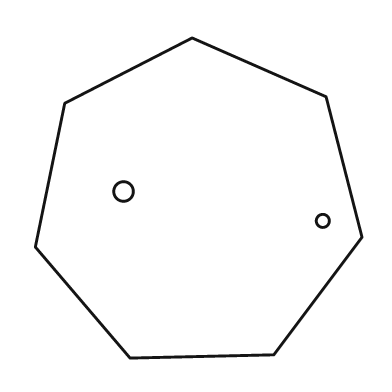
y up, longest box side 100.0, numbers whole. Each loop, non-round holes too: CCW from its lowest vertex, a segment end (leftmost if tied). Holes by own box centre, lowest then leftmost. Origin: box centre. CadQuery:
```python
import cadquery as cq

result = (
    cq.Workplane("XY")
    .moveTo(-21.0, -49.0)
    .lineTo(23.0, -48.0)
    .lineTo(50.0, -12.0)
    .lineTo(39.0, 31.0)
    .lineTo(-2.0, 49.0)
    .lineTo(-41.0, 29.0)
    .lineTo(-50.0, -15.0)
    .close()
    .moveTo(38.0, -7.0)
    .circle(2.0)
    .moveTo(-23.0, 2.0)
    .circle(3.0)
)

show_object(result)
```